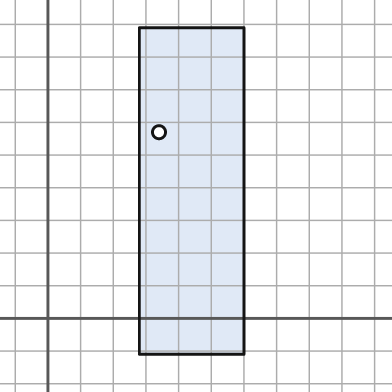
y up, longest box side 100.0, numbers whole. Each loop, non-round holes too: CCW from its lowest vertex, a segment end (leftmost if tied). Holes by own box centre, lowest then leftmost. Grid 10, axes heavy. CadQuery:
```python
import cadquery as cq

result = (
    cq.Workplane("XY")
    .moveTo(28.0, -11.0)
    .lineTo(60.0, -11.0)
    .lineTo(60.0, 89.0)
    .lineTo(28.0, 89.0)
    .close()
    .moveTo(34.0, 57.0)
    .circle(2.0)
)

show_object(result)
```